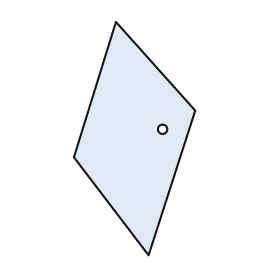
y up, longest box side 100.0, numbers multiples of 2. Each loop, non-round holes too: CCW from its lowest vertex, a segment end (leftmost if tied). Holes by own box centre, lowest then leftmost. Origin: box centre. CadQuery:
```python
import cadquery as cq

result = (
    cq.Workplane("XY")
    .moveTo(6.0, -50.0)
    .lineTo(26.0, 12.0)
    .lineTo(-8.0, 50.0)
    .lineTo(-26.0, -8.0)
    .close()
    .moveTo(12.0, 4.0)
    .circle(2.0)
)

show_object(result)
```